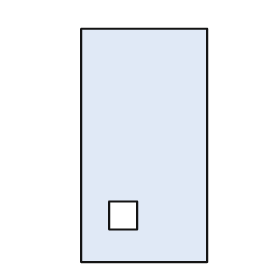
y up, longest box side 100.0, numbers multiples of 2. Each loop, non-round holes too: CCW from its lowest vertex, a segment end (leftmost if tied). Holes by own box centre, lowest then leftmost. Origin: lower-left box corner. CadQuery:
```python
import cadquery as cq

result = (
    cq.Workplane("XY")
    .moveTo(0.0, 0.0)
    .lineTo(54.0, 0.0)
    .lineTo(54.0, 100.0)
    .lineTo(0.0, 100.0)
    .close()
    .moveTo(12.0, 14.0)
    .lineTo(24.0, 14.0)
    .lineTo(24.0, 26.0)
    .lineTo(12.0, 26.0)
    .close()
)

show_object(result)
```